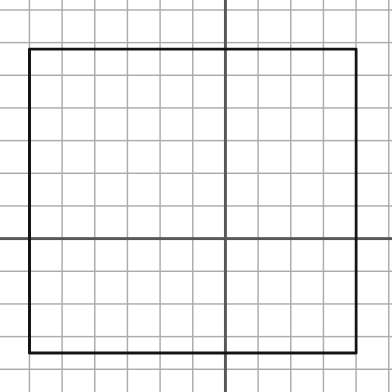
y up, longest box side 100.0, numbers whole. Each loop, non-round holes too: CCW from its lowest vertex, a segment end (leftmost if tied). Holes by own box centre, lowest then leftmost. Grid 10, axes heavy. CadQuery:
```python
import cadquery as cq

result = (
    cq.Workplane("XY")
    .moveTo(-60.0, -35.0)
    .lineTo(40.0, -35.0)
    .lineTo(40.0, 58.0)
    .lineTo(-60.0, 58.0)
    .close()
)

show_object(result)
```